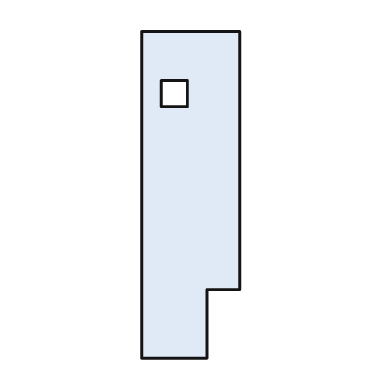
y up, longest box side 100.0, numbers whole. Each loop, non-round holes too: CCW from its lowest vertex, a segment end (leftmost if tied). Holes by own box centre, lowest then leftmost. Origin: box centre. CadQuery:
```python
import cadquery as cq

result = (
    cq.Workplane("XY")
    .moveTo(-15.0, -50.0)
    .lineTo(5.0, -50.0)
    .lineTo(5.0, -29.0)
    .lineTo(15.0, -29.0)
    .lineTo(15.0, 50.0)
    .lineTo(-15.0, 50.0)
    .close()
    .moveTo(-9.0, 27.0)
    .lineTo(-1.0, 27.0)
    .lineTo(-1.0, 35.0)
    .lineTo(-9.0, 35.0)
    .close()
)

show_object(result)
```